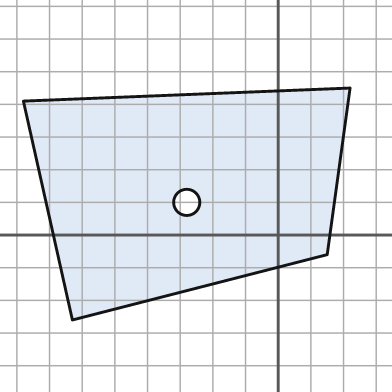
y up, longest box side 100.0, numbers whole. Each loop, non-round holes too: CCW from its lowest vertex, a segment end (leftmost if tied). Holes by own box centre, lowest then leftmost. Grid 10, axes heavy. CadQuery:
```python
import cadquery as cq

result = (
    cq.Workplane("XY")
    .moveTo(-63.0, -26.0)
    .lineTo(15.0, -6.0)
    .lineTo(22.0, 45.0)
    .lineTo(-78.0, 41.0)
    .close()
    .moveTo(-28.0, 10.0)
    .circle(4.0)
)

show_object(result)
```